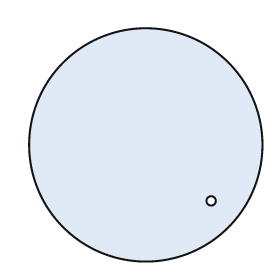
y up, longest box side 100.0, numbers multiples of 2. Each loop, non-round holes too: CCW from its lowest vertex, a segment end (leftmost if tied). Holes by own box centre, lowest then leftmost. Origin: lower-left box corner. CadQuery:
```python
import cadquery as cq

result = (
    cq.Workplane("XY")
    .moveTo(50.0, 50.0)
    .circle(50.0)
    .moveTo(78.0, 26.0)
    .circle(2.0)
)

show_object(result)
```